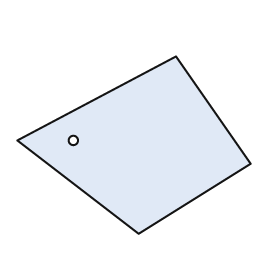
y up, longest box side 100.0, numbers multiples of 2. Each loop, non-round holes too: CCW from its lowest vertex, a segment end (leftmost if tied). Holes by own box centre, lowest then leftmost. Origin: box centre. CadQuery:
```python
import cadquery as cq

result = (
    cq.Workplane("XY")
    .moveTo(2.0, -38.0)
    .lineTo(50.0, -8.0)
    .lineTo(18.0, 38.0)
    .lineTo(-50.0, 2.0)
    .close()
    .moveTo(-26.0, 2.0)
    .circle(2.0)
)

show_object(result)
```